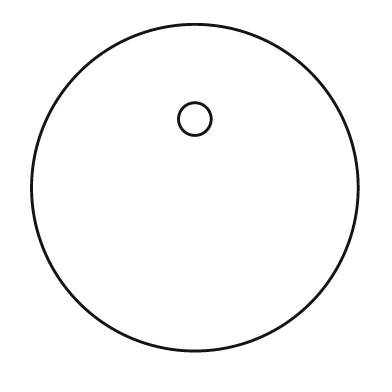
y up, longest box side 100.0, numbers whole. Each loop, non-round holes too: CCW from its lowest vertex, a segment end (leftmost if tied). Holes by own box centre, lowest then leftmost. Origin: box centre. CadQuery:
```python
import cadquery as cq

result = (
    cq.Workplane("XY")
    .moveTo(0.0, 0.0)
    .circle(50.0)
    .moveTo(0.0, 21.0)
    .circle(5.0)
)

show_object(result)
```